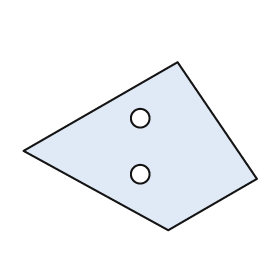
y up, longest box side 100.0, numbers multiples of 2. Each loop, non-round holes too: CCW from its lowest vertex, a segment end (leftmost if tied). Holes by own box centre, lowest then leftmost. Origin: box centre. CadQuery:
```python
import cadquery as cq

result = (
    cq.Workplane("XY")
    .moveTo(12.0, -36.0)
    .lineTo(50.0, -14.0)
    .lineTo(16.0, 36.0)
    .lineTo(-50.0, -2.0)
    .close()
    .moveTo(0.0, -12.0)
    .circle(4.0)
    .moveTo(0.0, 12.0)
    .circle(4.0)
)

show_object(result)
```